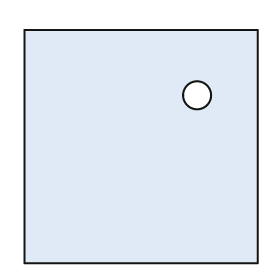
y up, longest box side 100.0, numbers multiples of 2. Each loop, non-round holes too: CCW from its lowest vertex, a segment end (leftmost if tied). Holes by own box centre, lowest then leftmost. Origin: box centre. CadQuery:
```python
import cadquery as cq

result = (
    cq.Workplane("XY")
    .moveTo(-50.0, -50.0)
    .lineTo(50.0, -50.0)
    .lineTo(50.0, 50.0)
    .lineTo(-50.0, 50.0)
    .close()
    .moveTo(24.0, 22.0)
    .circle(6.0)
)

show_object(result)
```